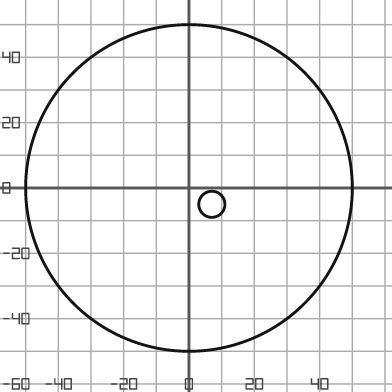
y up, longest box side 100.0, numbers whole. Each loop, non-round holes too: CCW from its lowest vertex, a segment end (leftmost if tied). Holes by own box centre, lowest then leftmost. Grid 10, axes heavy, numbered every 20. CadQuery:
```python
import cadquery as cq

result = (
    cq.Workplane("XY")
    .moveTo(0.0, 0.0)
    .circle(50.0)
    .moveTo(7.0, -5.0)
    .circle(4.0)
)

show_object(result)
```